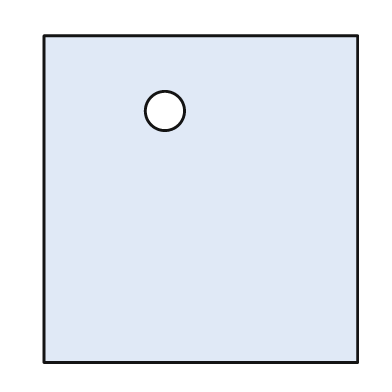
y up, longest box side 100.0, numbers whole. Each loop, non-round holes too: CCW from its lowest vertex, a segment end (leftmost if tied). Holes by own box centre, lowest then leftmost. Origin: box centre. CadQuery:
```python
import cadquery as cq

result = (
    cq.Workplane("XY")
    .moveTo(-48.0, -50.0)
    .lineTo(48.0, -50.0)
    .lineTo(48.0, 50.0)
    .lineTo(-48.0, 50.0)
    .close()
    .moveTo(-11.0, 27.0)
    .circle(6.0)
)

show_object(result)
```